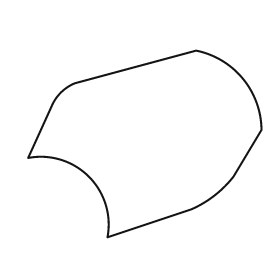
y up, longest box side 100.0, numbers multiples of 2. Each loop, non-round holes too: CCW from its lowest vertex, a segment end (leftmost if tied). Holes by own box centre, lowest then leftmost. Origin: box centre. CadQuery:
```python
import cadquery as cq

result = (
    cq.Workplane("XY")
    .moveTo(-16.0, -40.0)
    .lineTo(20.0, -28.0)
    .threePointArc((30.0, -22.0), (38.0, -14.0))
    .lineTo(50.0, 6.0)
    .threePointArc((42.0, 28.0), (22.0, 40.0))
    .lineTo(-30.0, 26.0)
    .threePointArc((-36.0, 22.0), (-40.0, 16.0))
    .lineTo(-50.0, -6.0)
    .threePointArc((-24.0, -14.0), (-16.0, -40.0))
    .close()
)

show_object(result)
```